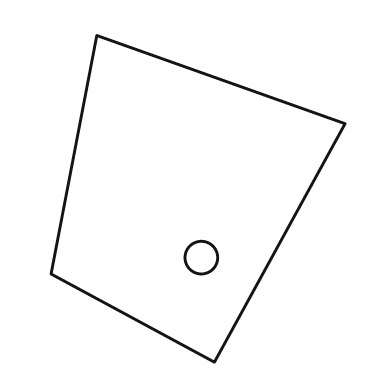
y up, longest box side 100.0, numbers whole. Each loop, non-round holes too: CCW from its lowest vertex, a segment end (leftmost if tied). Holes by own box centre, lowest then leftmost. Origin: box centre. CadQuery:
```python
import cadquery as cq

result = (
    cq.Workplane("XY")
    .moveTo(5.0, -50.0)
    .lineTo(45.0, 23.0)
    .lineTo(-31.0, 50.0)
    .lineTo(-45.0, -23.0)
    .close()
    .moveTo(1.0, -18.0)
    .circle(5.0)
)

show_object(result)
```